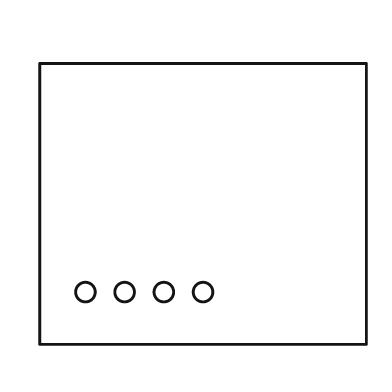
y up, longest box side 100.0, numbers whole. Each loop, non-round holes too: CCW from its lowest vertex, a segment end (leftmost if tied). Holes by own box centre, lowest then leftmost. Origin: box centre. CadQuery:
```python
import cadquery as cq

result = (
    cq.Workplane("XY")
    .moveTo(-50.0, -43.0)
    .lineTo(50.0, -43.0)
    .lineTo(50.0, 43.0)
    .lineTo(-50.0, 43.0)
    .close()
    .moveTo(-36.0, -27.0)
    .circle(3.0)
    .moveTo(-24.0, -27.0)
    .circle(3.0)
    .moveTo(-12.0, -27.0)
    .circle(3.0)
    .moveTo(0.0, -27.0)
    .circle(3.0)
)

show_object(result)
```